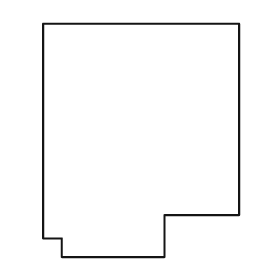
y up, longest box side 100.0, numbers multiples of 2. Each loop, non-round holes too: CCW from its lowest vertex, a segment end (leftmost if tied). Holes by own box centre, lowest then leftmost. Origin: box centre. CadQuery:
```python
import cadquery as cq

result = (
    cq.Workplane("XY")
    .moveTo(-34.0, -50.0)
    .lineTo(10.0, -50.0)
    .lineTo(10.0, -32.0)
    .lineTo(42.0, -32.0)
    .lineTo(42.0, 50.0)
    .lineTo(-42.0, 50.0)
    .lineTo(-42.0, -42.0)
    .lineTo(-34.0, -42.0)
    .close()
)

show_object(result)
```